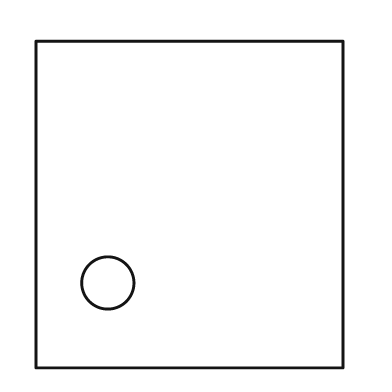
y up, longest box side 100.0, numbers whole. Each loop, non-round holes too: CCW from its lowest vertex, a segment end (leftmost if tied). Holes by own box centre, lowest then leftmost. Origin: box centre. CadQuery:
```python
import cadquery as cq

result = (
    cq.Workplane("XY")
    .moveTo(-47.0, -50.0)
    .lineTo(47.0, -50.0)
    .lineTo(47.0, 50.0)
    .lineTo(-47.0, 50.0)
    .close()
    .moveTo(-25.0, -24.0)
    .circle(8.0)
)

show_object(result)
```